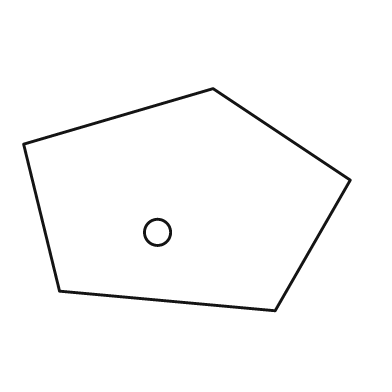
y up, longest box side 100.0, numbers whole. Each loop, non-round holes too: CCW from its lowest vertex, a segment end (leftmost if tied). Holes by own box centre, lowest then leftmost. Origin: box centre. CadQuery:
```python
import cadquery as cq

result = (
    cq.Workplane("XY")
    .moveTo(27.0, -34.0)
    .lineTo(50.0, 6.0)
    .lineTo(8.0, 34.0)
    .lineTo(-50.0, 17.0)
    .lineTo(-39.0, -28.0)
    .close()
    .moveTo(-9.0, -10.0)
    .circle(4.0)
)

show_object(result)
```